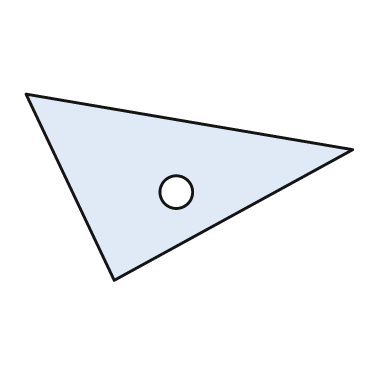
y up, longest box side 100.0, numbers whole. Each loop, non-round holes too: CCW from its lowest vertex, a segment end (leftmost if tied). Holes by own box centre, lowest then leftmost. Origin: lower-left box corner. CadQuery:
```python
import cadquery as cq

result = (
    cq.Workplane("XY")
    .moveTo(27.0, 0.0)
    .lineTo(100.0, 40.0)
    .lineTo(0.0, 57.0)
    .close()
    .moveTo(46.0, 27.0)
    .circle(5.0)
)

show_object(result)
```